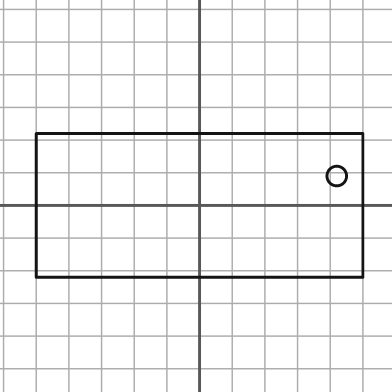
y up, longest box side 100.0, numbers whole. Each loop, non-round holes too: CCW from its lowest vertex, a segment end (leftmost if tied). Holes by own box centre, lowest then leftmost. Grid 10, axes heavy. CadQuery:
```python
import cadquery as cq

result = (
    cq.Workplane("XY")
    .moveTo(-50.0, -22.0)
    .lineTo(50.0, -22.0)
    .lineTo(50.0, 22.0)
    .lineTo(-50.0, 22.0)
    .close()
    .moveTo(42.0, 9.0)
    .circle(3.0)
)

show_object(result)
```